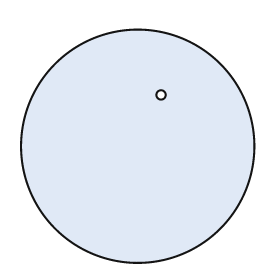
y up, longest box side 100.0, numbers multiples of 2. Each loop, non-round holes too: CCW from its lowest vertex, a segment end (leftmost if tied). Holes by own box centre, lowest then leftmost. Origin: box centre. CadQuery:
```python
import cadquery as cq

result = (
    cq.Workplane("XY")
    .moveTo(0.0, 0.0)
    .circle(50.0)
    .moveTo(10.0, 22.0)
    .circle(2.0)
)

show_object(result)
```